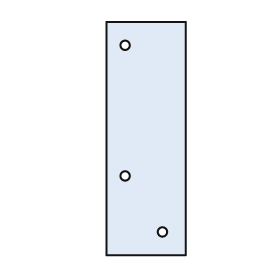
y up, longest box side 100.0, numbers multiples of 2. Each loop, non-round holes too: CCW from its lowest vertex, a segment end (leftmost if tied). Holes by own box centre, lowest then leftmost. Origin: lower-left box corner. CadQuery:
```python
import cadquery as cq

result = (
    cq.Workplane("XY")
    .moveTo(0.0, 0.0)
    .lineTo(34.0, 0.0)
    .lineTo(34.0, 100.0)
    .lineTo(0.0, 100.0)
    .close()
    .moveTo(24.0, 10.0)
    .circle(2.0)
    .moveTo(8.0, 34.0)
    .circle(2.0)
    .moveTo(8.0, 90.0)
    .circle(2.0)
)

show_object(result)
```